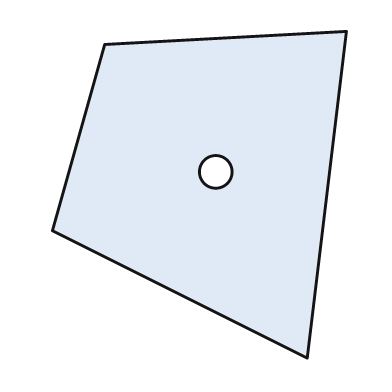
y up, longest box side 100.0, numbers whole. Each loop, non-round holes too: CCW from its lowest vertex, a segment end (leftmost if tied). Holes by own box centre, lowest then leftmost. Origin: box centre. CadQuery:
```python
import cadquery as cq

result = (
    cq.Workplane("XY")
    .moveTo(33.0, -50.0)
    .lineTo(45.0, 50.0)
    .lineTo(-29.0, 46.0)
    .lineTo(-45.0, -11.0)
    .close()
    .moveTo(5.0, 7.0)
    .circle(5.0)
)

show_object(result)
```